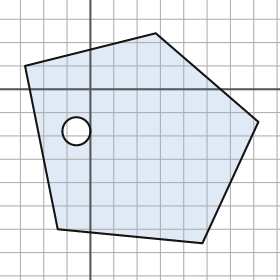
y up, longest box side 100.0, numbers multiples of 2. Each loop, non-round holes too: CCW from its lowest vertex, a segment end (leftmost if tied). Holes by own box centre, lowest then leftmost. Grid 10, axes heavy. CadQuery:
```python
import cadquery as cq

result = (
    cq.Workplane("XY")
    .moveTo(48.0, -66.0)
    .lineTo(72.0, -14.0)
    .lineTo(28.0, 24.0)
    .lineTo(-28.0, 10.0)
    .lineTo(-14.0, -60.0)
    .close()
    .moveTo(-6.0, -18.0)
    .circle(6.0)
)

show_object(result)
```